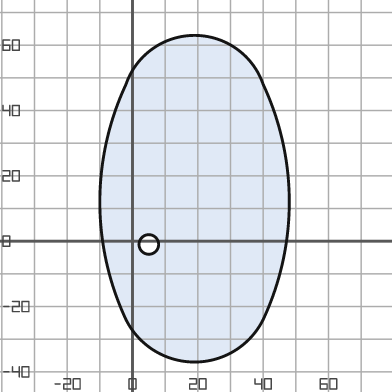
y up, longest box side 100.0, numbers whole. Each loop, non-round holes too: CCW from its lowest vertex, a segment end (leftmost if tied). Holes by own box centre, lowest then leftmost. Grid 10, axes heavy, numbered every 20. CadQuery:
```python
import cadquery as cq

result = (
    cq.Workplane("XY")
    .moveTo(-2.0, -24.0)
    .threePointArc((19.0, -37.0), (40.0, -24.0))
    .threePointArc((48.0, 12.0), (40.0, 48.0))
    .threePointArc((19.0, 63.0), (-2.0, 48.0))
    .threePointArc((-10.0, 12.0), (-2.0, -24.0))
    .close()
    .moveTo(5.0, -1.0)
    .circle(3.0)
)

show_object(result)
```